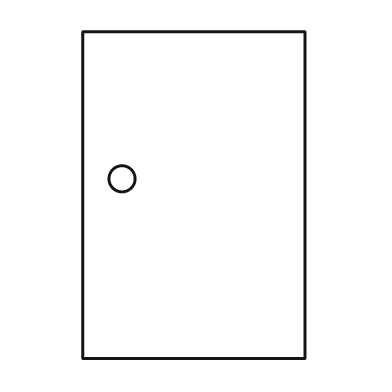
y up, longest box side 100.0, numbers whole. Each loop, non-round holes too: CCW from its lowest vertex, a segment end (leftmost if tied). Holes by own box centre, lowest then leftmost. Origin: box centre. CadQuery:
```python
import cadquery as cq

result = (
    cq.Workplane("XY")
    .moveTo(-34.0, -50.0)
    .lineTo(34.0, -50.0)
    .lineTo(34.0, 50.0)
    .lineTo(-34.0, 50.0)
    .close()
    .moveTo(-22.0, 5.0)
    .circle(4.0)
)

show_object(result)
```